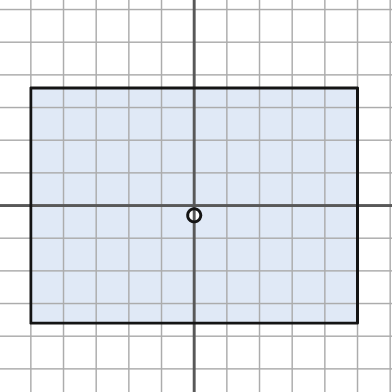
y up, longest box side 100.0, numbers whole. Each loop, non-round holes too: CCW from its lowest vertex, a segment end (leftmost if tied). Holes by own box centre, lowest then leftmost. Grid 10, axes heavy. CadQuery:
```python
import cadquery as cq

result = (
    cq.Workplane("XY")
    .moveTo(-50.0, -36.0)
    .lineTo(50.0, -36.0)
    .lineTo(50.0, 36.0)
    .lineTo(-50.0, 36.0)
    .close()
    .moveTo(0.0, -3.0)
    .circle(2.0)
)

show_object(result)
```